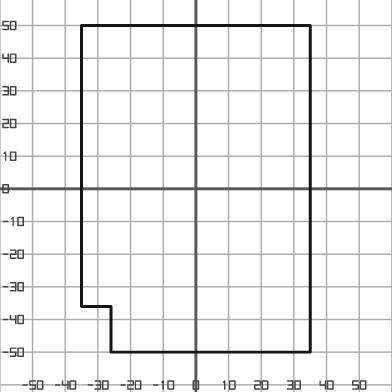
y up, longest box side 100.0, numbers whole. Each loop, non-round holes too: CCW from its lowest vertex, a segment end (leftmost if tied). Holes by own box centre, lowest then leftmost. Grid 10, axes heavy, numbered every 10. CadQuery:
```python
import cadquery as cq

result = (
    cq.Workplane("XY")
    .moveTo(-26.0, -50.0)
    .lineTo(35.0, -50.0)
    .lineTo(35.0, 50.0)
    .lineTo(-35.0, 50.0)
    .lineTo(-35.0, -36.0)
    .lineTo(-26.0, -36.0)
    .close()
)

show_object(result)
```